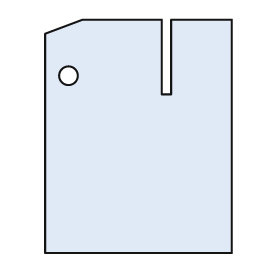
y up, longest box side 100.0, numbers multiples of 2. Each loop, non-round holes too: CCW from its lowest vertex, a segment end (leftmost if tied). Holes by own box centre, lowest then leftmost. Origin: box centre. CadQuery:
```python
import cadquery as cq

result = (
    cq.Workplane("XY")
    .moveTo(-40.0, -50.0)
    .lineTo(40.0, -50.0)
    .lineTo(40.0, 50.0)
    .lineTo(14.0, 50.0)
    .lineTo(14.0, 18.0)
    .lineTo(10.0, 18.0)
    .lineTo(10.0, 50.0)
    .lineTo(-24.0, 50.0)
    .lineTo(-40.0, 44.0)
    .close()
    .moveTo(-30.0, 26.0)
    .circle(4.0)
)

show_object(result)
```